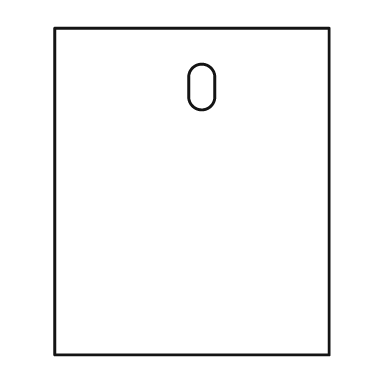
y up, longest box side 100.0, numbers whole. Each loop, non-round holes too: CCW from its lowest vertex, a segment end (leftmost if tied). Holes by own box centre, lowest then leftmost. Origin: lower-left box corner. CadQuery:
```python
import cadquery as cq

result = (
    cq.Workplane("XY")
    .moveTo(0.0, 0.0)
    .lineTo(84.0, 0.0)
    .lineTo(84.0, 100.0)
    .lineTo(0.0, 100.0)
    .close()
    .moveTo(41.0, 79.0)
    .threePointArc((45.0, 75.0), (49.0, 79.0))
    .lineTo(49.0, 85.0)
    .threePointArc((45.0, 89.0), (41.0, 85.0))
    .close()
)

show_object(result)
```